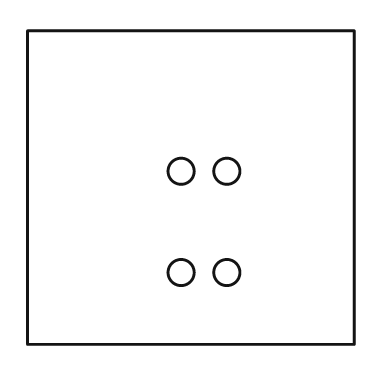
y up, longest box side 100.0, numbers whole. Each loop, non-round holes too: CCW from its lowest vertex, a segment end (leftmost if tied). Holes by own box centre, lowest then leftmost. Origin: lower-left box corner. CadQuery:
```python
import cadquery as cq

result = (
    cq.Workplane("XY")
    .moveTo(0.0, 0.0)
    .lineTo(100.0, 0.0)
    .lineTo(100.0, 96.0)
    .lineTo(0.0, 96.0)
    .close()
    .moveTo(47.0, 22.0)
    .circle(4.0)
    .moveTo(61.0, 22.0)
    .circle(4.0)
    .moveTo(47.0, 53.0)
    .circle(4.0)
    .moveTo(61.0, 53.0)
    .circle(4.0)
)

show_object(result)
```